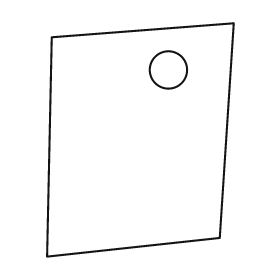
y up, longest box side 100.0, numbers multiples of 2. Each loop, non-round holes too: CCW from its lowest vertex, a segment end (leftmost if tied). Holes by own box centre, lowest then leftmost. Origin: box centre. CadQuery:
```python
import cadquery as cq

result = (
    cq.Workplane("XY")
    .moveTo(-40.0, -50.0)
    .lineTo(34.0, -42.0)
    .lineTo(40.0, 50.0)
    .lineTo(-38.0, 44.0)
    .close()
    .moveTo(12.0, 30.0)
    .circle(8.0)
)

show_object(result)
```